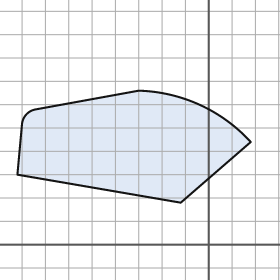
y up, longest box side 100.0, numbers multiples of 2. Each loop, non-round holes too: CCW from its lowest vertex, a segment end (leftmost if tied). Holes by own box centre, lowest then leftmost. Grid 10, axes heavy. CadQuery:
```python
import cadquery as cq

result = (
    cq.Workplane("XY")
    .moveTo(-12.0, 18.0)
    .lineTo(18.0, 44.0)
    .threePointArc((-4.0, 60.0), (-30.0, 66.0))
    .lineTo(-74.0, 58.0)
    .threePointArc((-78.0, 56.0), (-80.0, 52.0))
    .lineTo(-82.0, 30.0)
    .close()
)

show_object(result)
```